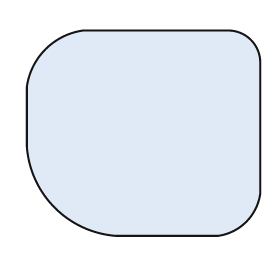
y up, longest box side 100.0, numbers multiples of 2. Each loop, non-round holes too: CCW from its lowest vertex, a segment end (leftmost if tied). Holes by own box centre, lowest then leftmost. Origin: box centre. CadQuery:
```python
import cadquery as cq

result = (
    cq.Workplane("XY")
    .moveTo(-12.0, -44.0)
    .lineTo(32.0, -44.0)
    .threePointArc((44.0, -38.0), (50.0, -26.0))
    .lineTo(50.0, 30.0)
    .threePointArc((46.0, 40.0), (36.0, 44.0))
    .lineTo(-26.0, 44.0)
    .threePointArc((-42.0, 36.0), (-50.0, 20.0))
    .lineTo(-50.0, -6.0)
    .threePointArc((-38.0, -32.0), (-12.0, -44.0))
    .close()
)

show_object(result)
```